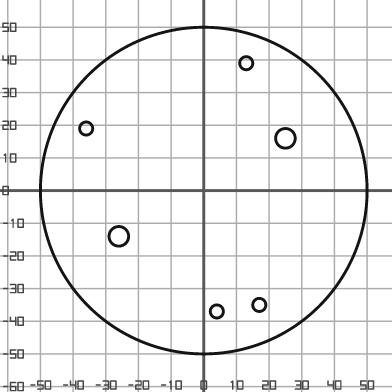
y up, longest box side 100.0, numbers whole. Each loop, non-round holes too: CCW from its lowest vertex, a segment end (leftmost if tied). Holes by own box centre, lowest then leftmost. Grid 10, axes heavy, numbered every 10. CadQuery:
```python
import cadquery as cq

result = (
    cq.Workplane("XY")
    .moveTo(0.0, 0.0)
    .circle(50.0)
    .moveTo(4.0, -37.0)
    .circle(2.0)
    .moveTo(17.0, -35.0)
    .circle(2.0)
    .moveTo(-26.0, -14.0)
    .circle(3.0)
    .moveTo(25.0, 16.0)
    .circle(3.0)
    .moveTo(-36.0, 19.0)
    .circle(2.0)
    .moveTo(13.0, 39.0)
    .circle(2.0)
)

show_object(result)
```